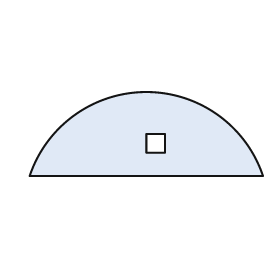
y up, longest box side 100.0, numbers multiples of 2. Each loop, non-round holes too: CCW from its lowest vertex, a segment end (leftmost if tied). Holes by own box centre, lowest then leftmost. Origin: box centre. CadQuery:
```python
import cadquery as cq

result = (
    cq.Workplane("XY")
    .moveTo(-50.0, -18.0)
    .lineTo(50.0, -18.0)
    .threePointArc((0.0, 18.0), (-50.0, -18.0))
    .close()
    .moveTo(0.0, -8.0)
    .lineTo(8.0, -8.0)
    .lineTo(8.0, 0.0)
    .lineTo(0.0, 0.0)
    .close()
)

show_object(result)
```